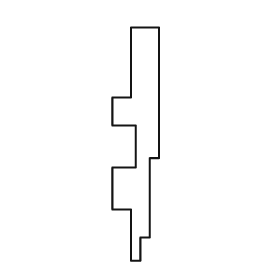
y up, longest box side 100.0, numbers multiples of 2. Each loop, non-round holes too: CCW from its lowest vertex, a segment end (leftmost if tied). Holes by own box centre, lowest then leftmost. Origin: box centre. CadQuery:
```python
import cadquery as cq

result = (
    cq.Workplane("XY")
    .moveTo(-2.0, -50.0)
    .lineTo(2.0, -50.0)
    .lineTo(2.0, -40.0)
    .lineTo(6.0, -40.0)
    .lineTo(6.0, -6.0)
    .lineTo(10.0, -6.0)
    .lineTo(10.0, 50.0)
    .lineTo(-2.0, 50.0)
    .lineTo(-2.0, 20.0)
    .lineTo(-10.0, 20.0)
    .lineTo(-10.0, 8.0)
    .lineTo(0.0, 8.0)
    .lineTo(0.0, -10.0)
    .lineTo(-10.0, -10.0)
    .lineTo(-10.0, -28.0)
    .lineTo(-2.0, -28.0)
    .close()
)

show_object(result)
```